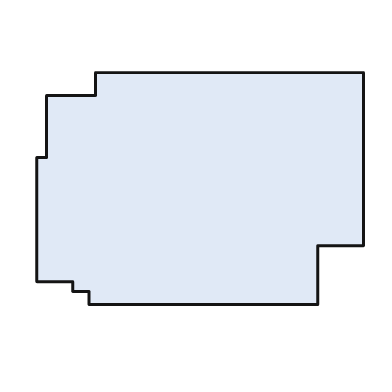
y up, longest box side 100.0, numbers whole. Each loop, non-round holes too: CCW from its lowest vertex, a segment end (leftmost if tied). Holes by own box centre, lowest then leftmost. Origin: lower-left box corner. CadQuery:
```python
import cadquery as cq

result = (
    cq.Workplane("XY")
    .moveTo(16.0, 0.0)
    .lineTo(86.0, 0.0)
    .lineTo(86.0, 18.0)
    .lineTo(100.0, 18.0)
    .lineTo(100.0, 71.0)
    .lineTo(18.0, 71.0)
    .lineTo(18.0, 64.0)
    .lineTo(3.0, 64.0)
    .lineTo(3.0, 45.0)
    .lineTo(0.0, 45.0)
    .lineTo(0.0, 7.0)
    .lineTo(11.0, 7.0)
    .lineTo(11.0, 4.0)
    .lineTo(16.0, 4.0)
    .close()
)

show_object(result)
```